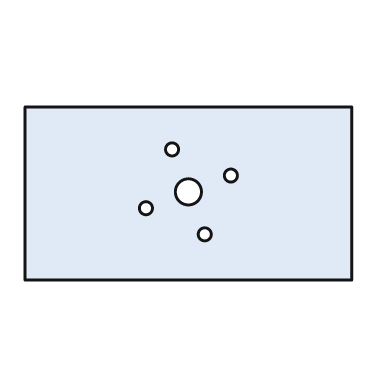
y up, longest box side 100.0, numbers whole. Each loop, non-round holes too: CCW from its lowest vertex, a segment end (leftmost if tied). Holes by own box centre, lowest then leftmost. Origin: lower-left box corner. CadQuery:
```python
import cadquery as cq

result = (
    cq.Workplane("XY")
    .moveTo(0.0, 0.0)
    .lineTo(100.0, 0.0)
    .lineTo(100.0, 53.0)
    .lineTo(0.0, 53.0)
    .close()
    .moveTo(55.0, 14.0)
    .circle(2.0)
    .moveTo(37.0, 22.0)
    .circle(2.0)
    .moveTo(50.0, 27.0)
    .circle(4.0)
    .moveTo(63.0, 32.0)
    .circle(2.0)
    .moveTo(45.0, 40.0)
    .circle(2.0)
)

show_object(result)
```